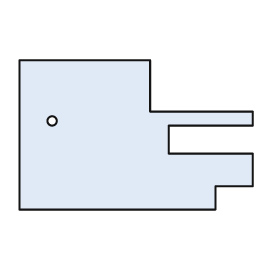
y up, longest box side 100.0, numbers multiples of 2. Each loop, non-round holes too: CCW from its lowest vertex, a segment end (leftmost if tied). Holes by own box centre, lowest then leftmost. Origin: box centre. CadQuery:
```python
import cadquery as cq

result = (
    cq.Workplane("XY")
    .moveTo(-50.0, -32.0)
    .lineTo(34.0, -32.0)
    .lineTo(34.0, -22.0)
    .lineTo(50.0, -22.0)
    .lineTo(50.0, -8.0)
    .lineTo(14.0, -8.0)
    .lineTo(14.0, 4.0)
    .lineTo(50.0, 4.0)
    .lineTo(50.0, 10.0)
    .lineTo(6.0, 10.0)
    .lineTo(6.0, 32.0)
    .lineTo(-50.0, 32.0)
    .close()
    .moveTo(-36.0, 6.0)
    .circle(2.0)
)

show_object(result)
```